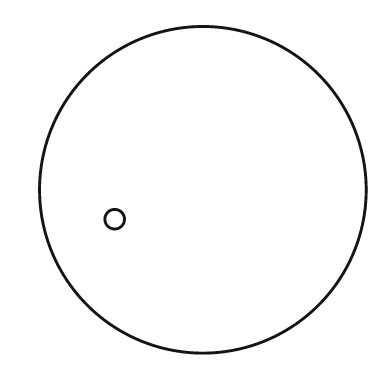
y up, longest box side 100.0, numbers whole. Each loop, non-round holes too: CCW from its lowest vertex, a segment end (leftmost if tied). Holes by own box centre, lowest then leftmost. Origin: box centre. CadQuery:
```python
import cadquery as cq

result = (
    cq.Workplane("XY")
    .moveTo(0.0, 0.0)
    .circle(50.0)
    .moveTo(-27.0, -9.0)
    .circle(3.0)
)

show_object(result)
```